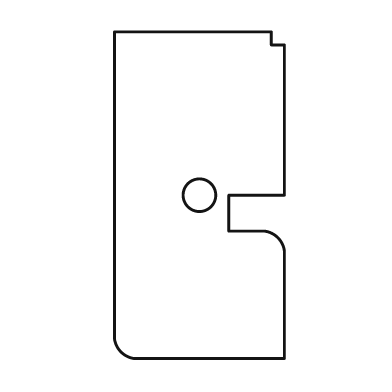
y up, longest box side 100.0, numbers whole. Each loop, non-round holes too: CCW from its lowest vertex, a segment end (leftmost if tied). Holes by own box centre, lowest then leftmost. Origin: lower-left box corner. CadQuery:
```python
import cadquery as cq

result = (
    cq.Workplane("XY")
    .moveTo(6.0, 0.0)
    .lineTo(52.0, 0.0)
    .lineTo(52.0, 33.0)
    .threePointArc((50.0, 37.0), (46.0, 39.0))
    .lineTo(35.0, 39.0)
    .lineTo(35.0, 50.0)
    .lineTo(52.0, 50.0)
    .lineTo(52.0, 96.0)
    .lineTo(48.0, 96.0)
    .lineTo(48.0, 100.0)
    .lineTo(0.0, 100.0)
    .lineTo(0.0, 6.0)
    .threePointArc((2.0, 2.0), (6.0, 0.0))
    .close()
    .moveTo(26.0, 50.0)
    .circle(5.0)
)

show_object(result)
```